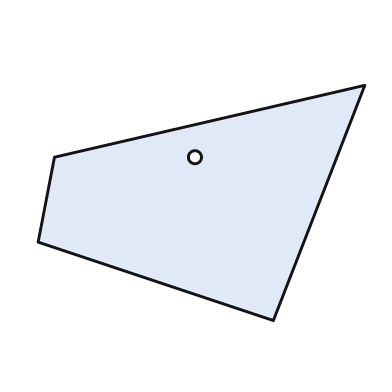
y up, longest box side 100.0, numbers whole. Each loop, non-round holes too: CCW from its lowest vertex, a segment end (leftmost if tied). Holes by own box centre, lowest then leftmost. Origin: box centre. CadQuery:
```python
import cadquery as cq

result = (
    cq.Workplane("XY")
    .moveTo(22.0, -36.0)
    .lineTo(50.0, 36.0)
    .lineTo(-45.0, 14.0)
    .lineTo(-50.0, -12.0)
    .close()
    .moveTo(-2.0, 14.0)
    .circle(2.0)
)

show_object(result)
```